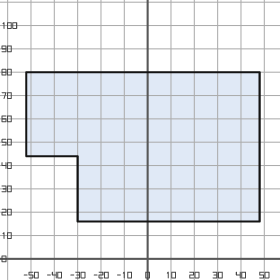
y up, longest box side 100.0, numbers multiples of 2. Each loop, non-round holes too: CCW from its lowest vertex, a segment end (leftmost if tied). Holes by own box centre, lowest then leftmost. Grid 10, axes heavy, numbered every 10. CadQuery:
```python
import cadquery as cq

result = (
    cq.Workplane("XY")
    .moveTo(-30.0, 16.0)
    .lineTo(48.0, 16.0)
    .lineTo(48.0, 80.0)
    .lineTo(-52.0, 80.0)
    .lineTo(-52.0, 44.0)
    .lineTo(-30.0, 44.0)
    .close()
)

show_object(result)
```